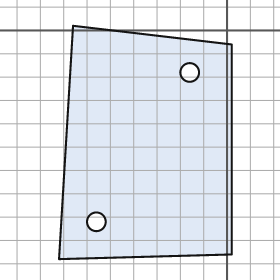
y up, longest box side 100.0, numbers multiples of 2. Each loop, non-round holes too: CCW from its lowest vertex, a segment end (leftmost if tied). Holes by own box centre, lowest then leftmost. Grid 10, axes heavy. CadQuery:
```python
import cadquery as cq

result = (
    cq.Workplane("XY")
    .moveTo(-72.0, -98.0)
    .lineTo(2.0, -96.0)
    .lineTo(2.0, -6.0)
    .lineTo(-66.0, 2.0)
    .close()
    .moveTo(-56.0, -82.0)
    .circle(4.0)
    .moveTo(-16.0, -18.0)
    .circle(4.0)
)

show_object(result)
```